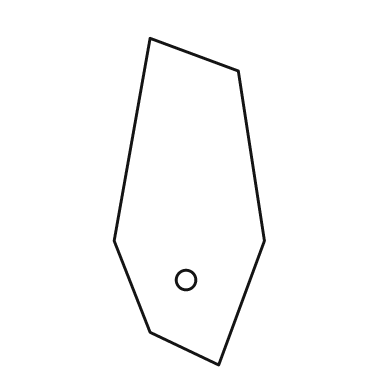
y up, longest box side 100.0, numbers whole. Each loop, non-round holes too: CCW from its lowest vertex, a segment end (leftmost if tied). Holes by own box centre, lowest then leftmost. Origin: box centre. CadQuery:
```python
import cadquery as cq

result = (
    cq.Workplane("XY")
    .moveTo(9.0, -50.0)
    .lineTo(23.0, -12.0)
    .lineTo(15.0, 40.0)
    .lineTo(-12.0, 50.0)
    .lineTo(-23.0, -12.0)
    .lineTo(-12.0, -40.0)
    .close()
    .moveTo(-1.0, -24.0)
    .circle(3.0)
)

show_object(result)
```